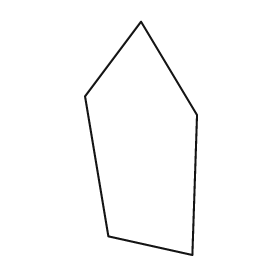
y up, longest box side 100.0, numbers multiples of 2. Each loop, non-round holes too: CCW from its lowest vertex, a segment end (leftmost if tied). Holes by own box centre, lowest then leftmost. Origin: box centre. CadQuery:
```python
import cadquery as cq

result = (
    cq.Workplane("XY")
    .moveTo(22.0, -50.0)
    .lineTo(24.0, 10.0)
    .lineTo(0.0, 50.0)
    .lineTo(-24.0, 18.0)
    .lineTo(-14.0, -42.0)
    .close()
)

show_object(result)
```